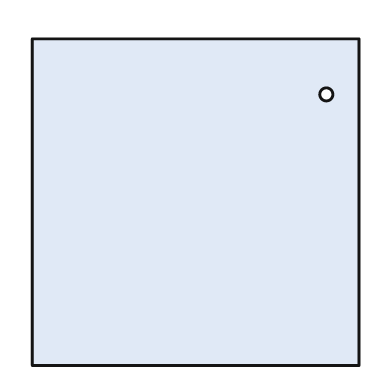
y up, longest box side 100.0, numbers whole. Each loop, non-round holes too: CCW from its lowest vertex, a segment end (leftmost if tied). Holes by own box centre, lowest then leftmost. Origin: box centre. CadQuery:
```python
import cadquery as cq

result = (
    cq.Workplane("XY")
    .moveTo(-50.0, -50.0)
    .lineTo(50.0, -50.0)
    .lineTo(50.0, 50.0)
    .lineTo(-50.0, 50.0)
    .close()
    .moveTo(40.0, 33.0)
    .circle(2.0)
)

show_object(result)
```